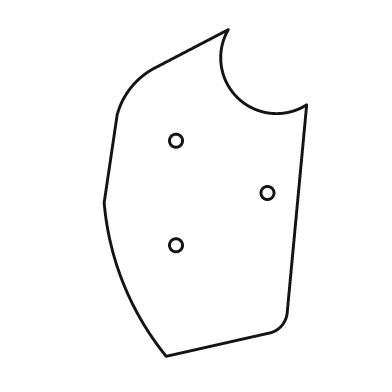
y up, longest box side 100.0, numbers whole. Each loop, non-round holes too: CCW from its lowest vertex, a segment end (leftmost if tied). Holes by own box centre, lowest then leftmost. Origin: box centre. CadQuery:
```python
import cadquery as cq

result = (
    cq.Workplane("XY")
    .moveTo(-12.0, -50.0)
    .lineTo(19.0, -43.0)
    .threePointArc((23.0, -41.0), (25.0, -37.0))
    .lineTo(31.0, 27.0)
    .threePointArc((10.0, 29.0), (7.0, 50.0))
    .lineTo(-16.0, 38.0)
    .threePointArc((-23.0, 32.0), (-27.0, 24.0))
    .lineTo(-31.0, -3.0)
    .threePointArc((-25.0, -28.0), (-12.0, -50.0))
    .close()
    .moveTo(-9.0, -16.0)
    .circle(2.0)
    .moveTo(19.0, 0.0)
    .circle(2.0)
    .moveTo(-9.0, 16.0)
    .circle(2.0)
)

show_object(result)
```